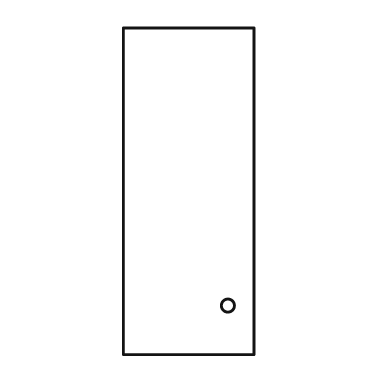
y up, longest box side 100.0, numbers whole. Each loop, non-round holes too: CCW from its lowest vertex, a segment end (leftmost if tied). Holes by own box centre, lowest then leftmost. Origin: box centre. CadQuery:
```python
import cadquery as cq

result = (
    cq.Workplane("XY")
    .moveTo(-20.0, -50.0)
    .lineTo(20.0, -50.0)
    .lineTo(20.0, 50.0)
    .lineTo(-20.0, 50.0)
    .close()
    .moveTo(12.0, -35.0)
    .circle(2.0)
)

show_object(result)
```